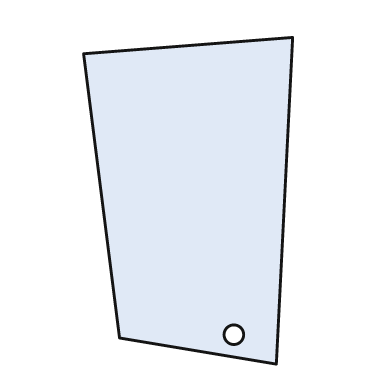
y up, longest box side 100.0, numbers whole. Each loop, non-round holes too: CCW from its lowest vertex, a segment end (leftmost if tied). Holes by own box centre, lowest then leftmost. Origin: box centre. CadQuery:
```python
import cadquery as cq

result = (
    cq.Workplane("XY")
    .moveTo(27.0, -50.0)
    .lineTo(32.0, 50.0)
    .lineTo(-32.0, 45.0)
    .lineTo(-21.0, -42.0)
    .close()
    .moveTo(14.0, -41.0)
    .circle(3.0)
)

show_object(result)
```